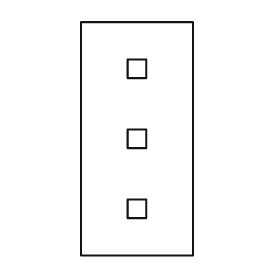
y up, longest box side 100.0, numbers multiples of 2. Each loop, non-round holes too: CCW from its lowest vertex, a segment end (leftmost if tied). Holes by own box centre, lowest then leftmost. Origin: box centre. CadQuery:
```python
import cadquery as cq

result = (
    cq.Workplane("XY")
    .moveTo(-24.0, -50.0)
    .lineTo(24.0, -50.0)
    .lineTo(24.0, 50.0)
    .lineTo(-24.0, 50.0)
    .close()
    .moveTo(-4.0, -34.0)
    .lineTo(4.0, -34.0)
    .lineTo(4.0, -26.0)
    .lineTo(-4.0, -26.0)
    .close()
    .moveTo(-4.0, -4.0)
    .lineTo(4.0, -4.0)
    .lineTo(4.0, 4.0)
    .lineTo(-4.0, 4.0)
    .close()
    .moveTo(-4.0, 26.0)
    .lineTo(4.0, 26.0)
    .lineTo(4.0, 34.0)
    .lineTo(-4.0, 34.0)
    .close()
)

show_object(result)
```